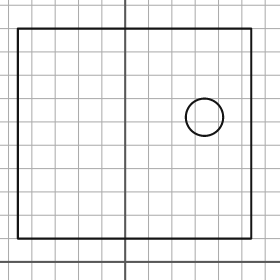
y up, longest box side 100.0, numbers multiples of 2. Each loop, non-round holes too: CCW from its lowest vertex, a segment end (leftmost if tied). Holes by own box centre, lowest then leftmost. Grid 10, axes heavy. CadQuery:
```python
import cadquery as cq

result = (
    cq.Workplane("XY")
    .moveTo(-46.0, 10.0)
    .lineTo(54.0, 10.0)
    .lineTo(54.0, 100.0)
    .lineTo(-46.0, 100.0)
    .close()
    .moveTo(34.0, 62.0)
    .circle(8.0)
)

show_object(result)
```